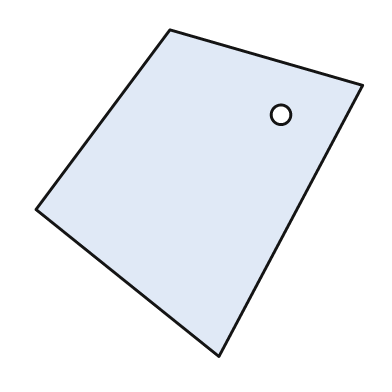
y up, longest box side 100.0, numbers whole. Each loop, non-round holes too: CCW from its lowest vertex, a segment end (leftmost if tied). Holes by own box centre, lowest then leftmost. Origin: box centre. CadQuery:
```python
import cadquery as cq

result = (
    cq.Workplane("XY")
    .moveTo(6.0, -50.0)
    .lineTo(50.0, 33.0)
    .lineTo(-9.0, 50.0)
    .lineTo(-50.0, -5.0)
    .close()
    .moveTo(25.0, 24.0)
    .circle(3.0)
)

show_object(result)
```